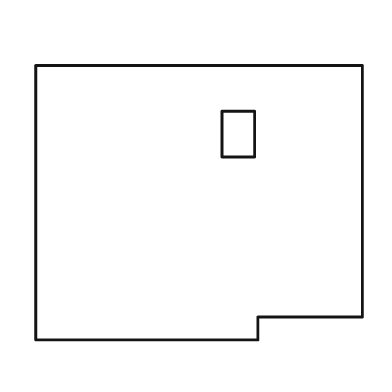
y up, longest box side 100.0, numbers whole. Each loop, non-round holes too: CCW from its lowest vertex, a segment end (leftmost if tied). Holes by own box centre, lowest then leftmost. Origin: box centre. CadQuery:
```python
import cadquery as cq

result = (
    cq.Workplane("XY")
    .moveTo(-50.0, -42.0)
    .lineTo(18.0, -42.0)
    .lineTo(18.0, -35.0)
    .lineTo(50.0, -35.0)
    .lineTo(50.0, 42.0)
    .lineTo(-50.0, 42.0)
    .close()
    .moveTo(7.0, 14.0)
    .lineTo(17.0, 14.0)
    .lineTo(17.0, 28.0)
    .lineTo(7.0, 28.0)
    .close()
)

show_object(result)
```